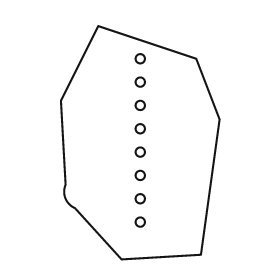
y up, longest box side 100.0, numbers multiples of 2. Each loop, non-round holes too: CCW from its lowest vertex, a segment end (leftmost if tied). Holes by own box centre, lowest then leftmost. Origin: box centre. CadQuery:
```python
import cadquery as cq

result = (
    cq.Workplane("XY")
    .moveTo(-8.0, -50.0)
    .lineTo(26.0, -48.0)
    .lineTo(34.0, 10.0)
    .lineTo(24.0, 36.0)
    .lineTo(-18.0, 50.0)
    .lineTo(-34.0, 18.0)
    .lineTo(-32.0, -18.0)
    .threePointArc((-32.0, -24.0), (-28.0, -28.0))
    .close()
    .moveTo(0.0, -34.0)
    .circle(2.0)
    .moveTo(0.0, -24.0)
    .circle(2.0)
    .moveTo(0.0, -14.0)
    .circle(2.0)
    .moveTo(0.0, -4.0)
    .circle(2.0)
    .moveTo(0.0, 6.0)
    .circle(2.0)
    .moveTo(0.0, 16.0)
    .circle(2.0)
    .moveTo(0.0, 26.0)
    .circle(2.0)
    .moveTo(0.0, 36.0)
    .circle(2.0)
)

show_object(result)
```